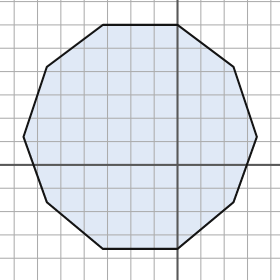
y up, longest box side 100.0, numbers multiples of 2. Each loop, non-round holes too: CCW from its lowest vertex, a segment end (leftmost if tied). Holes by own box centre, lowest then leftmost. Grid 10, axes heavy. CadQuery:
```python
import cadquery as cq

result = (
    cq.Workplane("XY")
    .moveTo(-32.0, -36.0)
    .lineTo(0.0, -36.0)
    .lineTo(24.0, -16.0)
    .lineTo(34.0, 12.0)
    .lineTo(24.0, 42.0)
    .lineTo(0.0, 60.0)
    .lineTo(-32.0, 60.0)
    .lineTo(-56.0, 42.0)
    .lineTo(-66.0, 12.0)
    .lineTo(-56.0, -16.0)
    .close()
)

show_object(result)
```